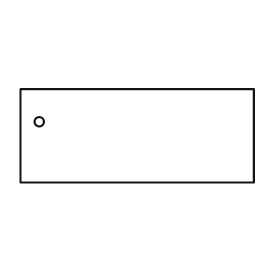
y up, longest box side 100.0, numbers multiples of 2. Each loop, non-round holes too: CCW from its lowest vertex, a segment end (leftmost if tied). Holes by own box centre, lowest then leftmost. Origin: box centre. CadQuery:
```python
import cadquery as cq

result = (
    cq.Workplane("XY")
    .moveTo(-50.0, -20.0)
    .lineTo(50.0, -20.0)
    .lineTo(50.0, 20.0)
    .lineTo(-50.0, 20.0)
    .close()
    .moveTo(-42.0, 6.0)
    .circle(2.0)
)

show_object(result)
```